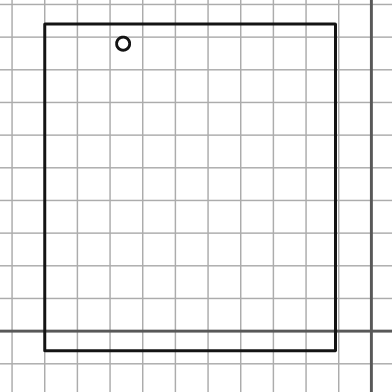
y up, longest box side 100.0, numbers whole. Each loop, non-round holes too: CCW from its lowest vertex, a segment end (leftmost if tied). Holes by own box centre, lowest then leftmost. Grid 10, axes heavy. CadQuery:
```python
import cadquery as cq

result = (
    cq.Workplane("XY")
    .moveTo(-100.0, -6.0)
    .lineTo(-11.0, -6.0)
    .lineTo(-11.0, 94.0)
    .lineTo(-100.0, 94.0)
    .close()
    .moveTo(-76.0, 88.0)
    .circle(2.0)
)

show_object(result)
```